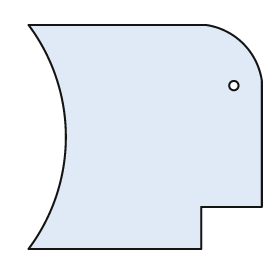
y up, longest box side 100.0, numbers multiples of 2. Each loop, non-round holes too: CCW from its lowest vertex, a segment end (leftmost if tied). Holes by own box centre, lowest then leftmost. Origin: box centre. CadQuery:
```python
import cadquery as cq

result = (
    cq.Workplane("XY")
    .moveTo(-50.0, -48.0)
    .lineTo(24.0, -48.0)
    .lineTo(24.0, -30.0)
    .lineTo(50.0, -30.0)
    .lineTo(50.0, 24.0)
    .threePointArc((42.0, 40.0), (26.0, 48.0))
    .lineTo(-50.0, 48.0)
    .threePointArc((-34.0, 0.0), (-50.0, -48.0))
    .close()
    .moveTo(38.0, 22.0)
    .circle(2.0)
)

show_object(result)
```